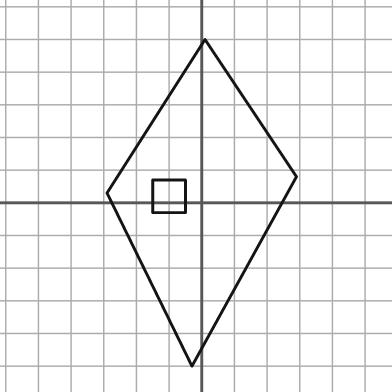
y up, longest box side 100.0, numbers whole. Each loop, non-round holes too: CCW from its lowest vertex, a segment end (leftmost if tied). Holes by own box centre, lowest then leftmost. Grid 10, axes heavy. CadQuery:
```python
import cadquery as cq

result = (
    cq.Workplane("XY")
    .moveTo(-3.0, -50.0)
    .lineTo(29.0, 8.0)
    .lineTo(1.0, 50.0)
    .lineTo(-29.0, 3.0)
    .close()
    .moveTo(-15.0, -3.0)
    .lineTo(-5.0, -3.0)
    .lineTo(-5.0, 7.0)
    .lineTo(-15.0, 7.0)
    .close()
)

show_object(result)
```